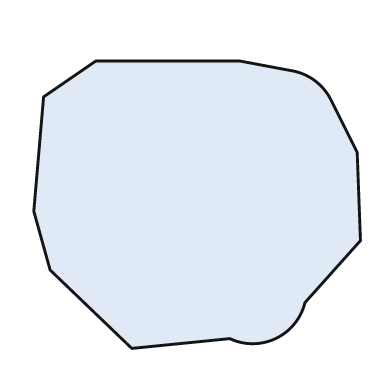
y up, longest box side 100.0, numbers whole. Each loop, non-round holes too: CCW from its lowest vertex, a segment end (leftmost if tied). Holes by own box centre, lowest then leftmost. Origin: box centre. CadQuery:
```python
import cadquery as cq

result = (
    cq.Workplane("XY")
    .moveTo(-20.0, -44.0)
    .lineTo(10.0, -41.0)
    .threePointArc((24.0, -41.0), (33.0, -30.0))
    .lineTo(50.0, -11.0)
    .lineTo(49.0, 16.0)
    .lineTo(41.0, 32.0)
    .threePointArc((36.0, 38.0), (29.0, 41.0))
    .lineTo(13.0, 44.0)
    .lineTo(-31.0, 44.0)
    .lineTo(-47.0, 33.0)
    .lineTo(-50.0, -2.0)
    .lineTo(-45.0, -20.0)
    .close()
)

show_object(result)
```